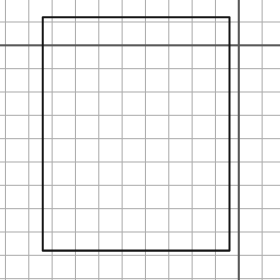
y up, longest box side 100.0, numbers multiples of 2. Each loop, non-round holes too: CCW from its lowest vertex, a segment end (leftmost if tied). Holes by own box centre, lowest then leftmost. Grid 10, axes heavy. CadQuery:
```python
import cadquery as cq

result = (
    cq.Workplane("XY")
    .moveTo(-84.0, -88.0)
    .lineTo(-4.0, -88.0)
    .lineTo(-4.0, 12.0)
    .lineTo(-84.0, 12.0)
    .close()
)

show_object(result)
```